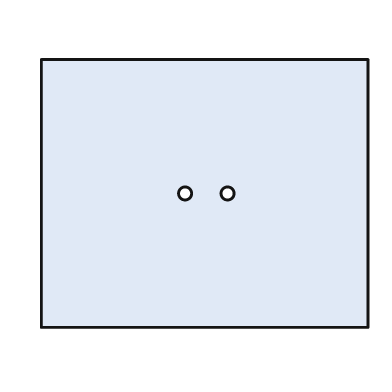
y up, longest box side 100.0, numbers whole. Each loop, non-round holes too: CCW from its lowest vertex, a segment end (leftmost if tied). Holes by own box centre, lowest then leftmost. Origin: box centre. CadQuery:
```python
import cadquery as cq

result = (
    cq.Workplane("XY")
    .moveTo(-50.0, -41.0)
    .lineTo(50.0, -41.0)
    .lineTo(50.0, 41.0)
    .lineTo(-50.0, 41.0)
    .close()
    .moveTo(-6.0, 0.0)
    .circle(2.0)
    .moveTo(7.0, 0.0)
    .circle(2.0)
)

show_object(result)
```